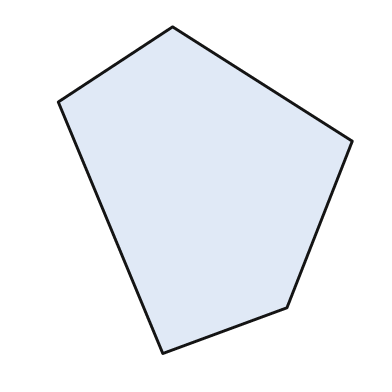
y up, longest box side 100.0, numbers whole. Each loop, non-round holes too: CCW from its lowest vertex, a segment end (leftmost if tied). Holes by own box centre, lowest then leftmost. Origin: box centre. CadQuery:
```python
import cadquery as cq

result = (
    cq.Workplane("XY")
    .moveTo(-13.0, -50.0)
    .lineTo(25.0, -36.0)
    .lineTo(45.0, 15.0)
    .lineTo(-10.0, 50.0)
    .lineTo(-45.0, 27.0)
    .close()
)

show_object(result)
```